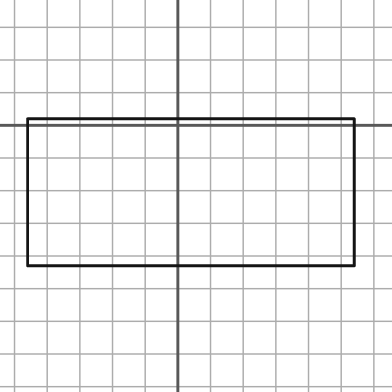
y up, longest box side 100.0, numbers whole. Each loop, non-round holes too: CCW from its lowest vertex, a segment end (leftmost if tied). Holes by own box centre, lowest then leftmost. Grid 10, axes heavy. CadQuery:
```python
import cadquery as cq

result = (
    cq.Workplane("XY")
    .moveTo(-46.0, -43.0)
    .lineTo(54.0, -43.0)
    .lineTo(54.0, 2.0)
    .lineTo(-46.0, 2.0)
    .close()
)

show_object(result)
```